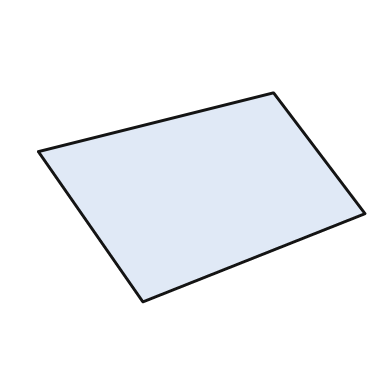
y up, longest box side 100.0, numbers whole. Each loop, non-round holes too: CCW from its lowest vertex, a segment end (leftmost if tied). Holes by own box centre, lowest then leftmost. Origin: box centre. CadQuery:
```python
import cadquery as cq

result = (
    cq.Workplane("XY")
    .moveTo(-18.0, -32.0)
    .lineTo(50.0, -5.0)
    .lineTo(22.0, 32.0)
    .lineTo(-50.0, 14.0)
    .close()
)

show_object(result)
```